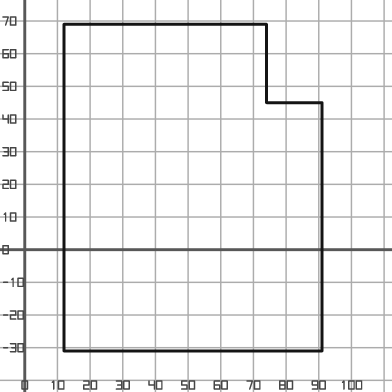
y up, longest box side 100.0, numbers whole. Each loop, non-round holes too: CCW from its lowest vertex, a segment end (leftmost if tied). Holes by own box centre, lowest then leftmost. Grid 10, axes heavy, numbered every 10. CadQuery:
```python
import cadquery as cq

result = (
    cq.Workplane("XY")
    .moveTo(12.0, -31.0)
    .lineTo(91.0, -31.0)
    .lineTo(91.0, 45.0)
    .lineTo(74.0, 45.0)
    .lineTo(74.0, 69.0)
    .lineTo(12.0, 69.0)
    .close()
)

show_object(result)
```